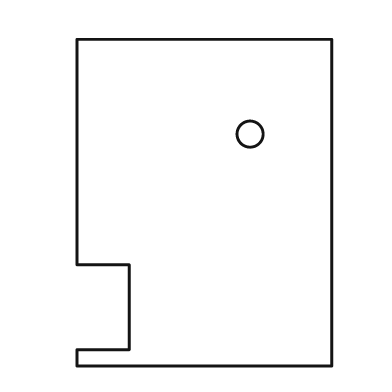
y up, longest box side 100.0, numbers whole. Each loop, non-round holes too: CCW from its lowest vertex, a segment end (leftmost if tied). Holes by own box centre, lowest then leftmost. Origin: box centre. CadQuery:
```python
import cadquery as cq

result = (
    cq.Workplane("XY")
    .moveTo(-39.0, -50.0)
    .lineTo(39.0, -50.0)
    .lineTo(39.0, 50.0)
    .lineTo(-39.0, 50.0)
    .lineTo(-39.0, -19.0)
    .lineTo(-23.0, -19.0)
    .lineTo(-23.0, -45.0)
    .lineTo(-39.0, -45.0)
    .close()
    .moveTo(14.0, 21.0)
    .circle(4.0)
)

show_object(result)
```